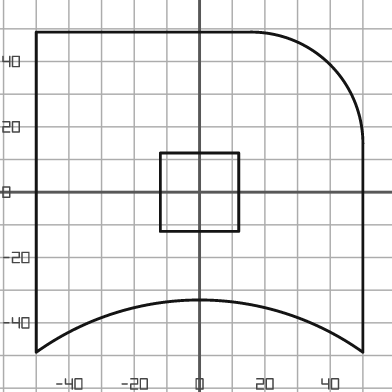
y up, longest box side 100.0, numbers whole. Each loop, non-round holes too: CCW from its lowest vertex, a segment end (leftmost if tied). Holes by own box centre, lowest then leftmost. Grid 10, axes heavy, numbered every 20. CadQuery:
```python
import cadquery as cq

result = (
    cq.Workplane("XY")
    .moveTo(-50.0, -49.0)
    .threePointArc((0.0, -33.0), (50.0, -49.0))
    .lineTo(50.0, 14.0)
    .threePointArc((40.0, 39.0), (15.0, 49.0))
    .lineTo(-50.0, 49.0)
    .close()
    .moveTo(-12.0, -12.0)
    .lineTo(12.0, -12.0)
    .lineTo(12.0, 12.0)
    .lineTo(-12.0, 12.0)
    .close()
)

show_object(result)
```